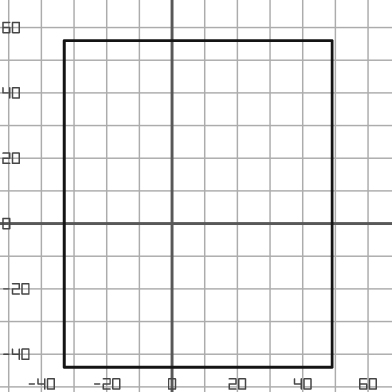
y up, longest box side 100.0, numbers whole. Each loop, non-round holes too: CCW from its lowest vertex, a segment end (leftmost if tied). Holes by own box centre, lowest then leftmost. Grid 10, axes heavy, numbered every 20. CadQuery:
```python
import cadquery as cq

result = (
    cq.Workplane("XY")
    .moveTo(-33.0, -44.0)
    .lineTo(49.0, -44.0)
    .lineTo(49.0, 56.0)
    .lineTo(-33.0, 56.0)
    .close()
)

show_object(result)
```